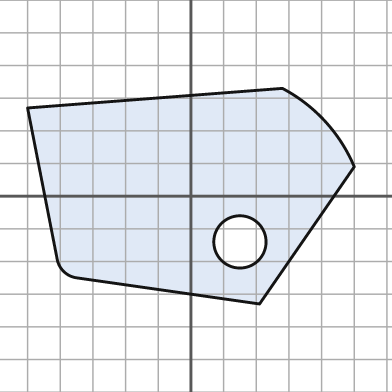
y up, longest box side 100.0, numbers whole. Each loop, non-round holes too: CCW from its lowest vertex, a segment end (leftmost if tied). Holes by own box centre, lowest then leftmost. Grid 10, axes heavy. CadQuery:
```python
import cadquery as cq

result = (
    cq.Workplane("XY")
    .moveTo(21.0, -33.0)
    .lineTo(50.0, 9.0)
    .threePointArc((41.0, 23.0), (28.0, 33.0))
    .lineTo(-50.0, 27.0)
    .lineTo(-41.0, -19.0)
    .threePointArc((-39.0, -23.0), (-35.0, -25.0))
    .close()
    .moveTo(15.0, -14.0)
    .circle(8.0)
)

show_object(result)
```